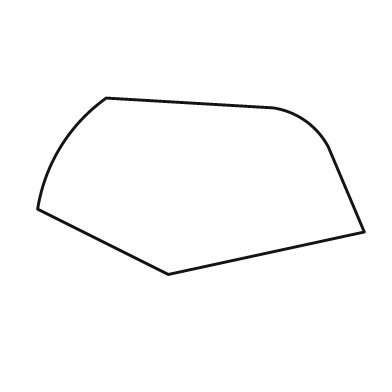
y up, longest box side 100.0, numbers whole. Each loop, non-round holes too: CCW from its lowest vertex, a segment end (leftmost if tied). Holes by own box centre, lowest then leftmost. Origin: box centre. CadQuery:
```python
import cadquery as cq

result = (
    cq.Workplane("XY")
    .moveTo(-10.0, -27.0)
    .lineTo(50.0, -14.0)
    .lineTo(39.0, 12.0)
    .threePointArc((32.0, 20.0), (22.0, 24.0))
    .lineTo(-29.0, 27.0)
    .threePointArc((-43.0, 12.0), (-50.0, -7.0))
    .close()
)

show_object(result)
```